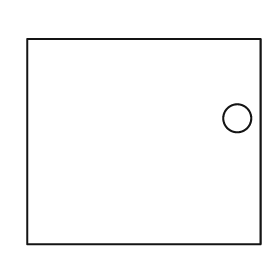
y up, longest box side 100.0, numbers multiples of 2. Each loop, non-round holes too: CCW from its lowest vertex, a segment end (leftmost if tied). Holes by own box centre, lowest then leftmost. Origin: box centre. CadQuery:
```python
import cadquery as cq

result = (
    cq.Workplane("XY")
    .moveTo(-50.0, -44.0)
    .lineTo(50.0, -44.0)
    .lineTo(50.0, 44.0)
    .lineTo(-50.0, 44.0)
    .close()
    .moveTo(40.0, 10.0)
    .circle(6.0)
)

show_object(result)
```